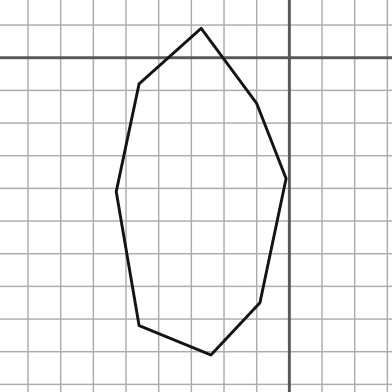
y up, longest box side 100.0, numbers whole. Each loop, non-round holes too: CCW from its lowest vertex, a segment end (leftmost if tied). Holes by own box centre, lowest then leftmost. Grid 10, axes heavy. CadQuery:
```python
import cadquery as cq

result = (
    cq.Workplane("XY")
    .moveTo(-24.0, -91.0)
    .lineTo(-9.0, -75.0)
    .lineTo(-1.0, -37.0)
    .lineTo(-10.0, -14.0)
    .lineTo(-27.0, 9.0)
    .lineTo(-46.0, -8.0)
    .lineTo(-53.0, -41.0)
    .lineTo(-46.0, -82.0)
    .close()
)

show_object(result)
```